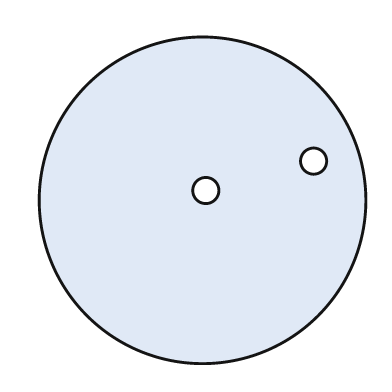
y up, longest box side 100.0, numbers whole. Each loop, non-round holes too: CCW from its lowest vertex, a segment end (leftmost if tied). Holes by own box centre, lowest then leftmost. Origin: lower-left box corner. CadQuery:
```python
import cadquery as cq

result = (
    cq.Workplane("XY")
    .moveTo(50.0, 50.0)
    .circle(50.0)
    .moveTo(51.0, 53.0)
    .circle(4.0)
    .moveTo(84.0, 62.0)
    .circle(4.0)
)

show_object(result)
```